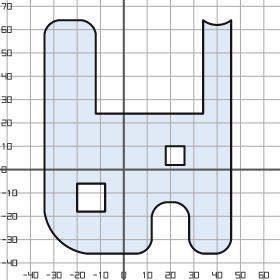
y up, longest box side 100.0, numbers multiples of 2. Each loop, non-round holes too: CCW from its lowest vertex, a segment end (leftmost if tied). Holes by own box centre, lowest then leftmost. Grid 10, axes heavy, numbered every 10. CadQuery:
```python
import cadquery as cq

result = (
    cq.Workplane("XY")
    .moveTo(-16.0, -36.0)
    .lineTo(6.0, -36.0)
    .threePointArc((10.0, -34.0), (12.0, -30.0))
    .lineTo(12.0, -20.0)
    .threePointArc((14.0, -16.0), (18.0, -14.0))
    .lineTo(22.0, -14.0)
    .threePointArc((26.0, -16.0), (28.0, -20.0))
    .lineTo(28.0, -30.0)
    .threePointArc((30.0, -34.0), (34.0, -36.0))
    .lineTo(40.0, -36.0)
    .threePointArc((44.0, -34.0), (46.0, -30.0))
    .lineTo(46.0, 64.0)
    .threePointArc((40.0, 62.0), (34.0, 64.0))
    .lineTo(34.0, 24.0)
    .lineTo(-12.0, 24.0)
    .lineTo(-12.0, 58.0)
    .threePointArc((-14.0, 62.0), (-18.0, 64.0))
    .lineTo(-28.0, 64.0)
    .threePointArc((-32.0, 62.0), (-34.0, 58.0))
    .lineTo(-34.0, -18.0)
    .threePointArc((-28.0, -30.0), (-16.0, -36.0))
    .close()
    .moveTo(-20.0, -18.0)
    .lineTo(-8.0, -18.0)
    .lineTo(-8.0, -6.0)
    .lineTo(-20.0, -6.0)
    .close()
    .moveTo(18.0, 2.0)
    .lineTo(26.0, 2.0)
    .lineTo(26.0, 10.0)
    .lineTo(18.0, 10.0)
    .close()
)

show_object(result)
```